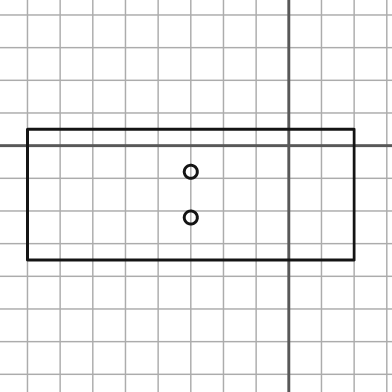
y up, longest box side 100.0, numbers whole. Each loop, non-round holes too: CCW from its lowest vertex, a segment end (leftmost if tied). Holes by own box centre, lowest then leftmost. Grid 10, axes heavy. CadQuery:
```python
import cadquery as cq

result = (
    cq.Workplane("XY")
    .moveTo(-80.0, -35.0)
    .lineTo(20.0, -35.0)
    .lineTo(20.0, 5.0)
    .lineTo(-80.0, 5.0)
    .close()
    .moveTo(-30.0, -22.0)
    .circle(2.0)
    .moveTo(-30.0, -8.0)
    .circle(2.0)
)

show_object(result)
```